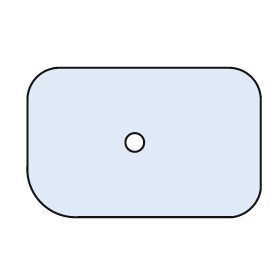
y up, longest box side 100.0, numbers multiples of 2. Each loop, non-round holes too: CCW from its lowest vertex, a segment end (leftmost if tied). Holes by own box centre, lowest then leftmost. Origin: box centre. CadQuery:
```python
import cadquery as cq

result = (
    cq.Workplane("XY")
    .moveTo(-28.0, -32.0)
    .lineTo(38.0, -32.0)
    .threePointArc((46.0, -28.0), (50.0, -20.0))
    .lineTo(50.0, 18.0)
    .threePointArc((46.0, 28.0), (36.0, 32.0))
    .lineTo(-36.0, 32.0)
    .threePointArc((-46.0, 28.0), (-50.0, 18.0))
    .lineTo(-50.0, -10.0)
    .threePointArc((-44.0, -26.0), (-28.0, -32.0))
    .close()
    .moveTo(-4.0, 0.0)
    .circle(4.0)
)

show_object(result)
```